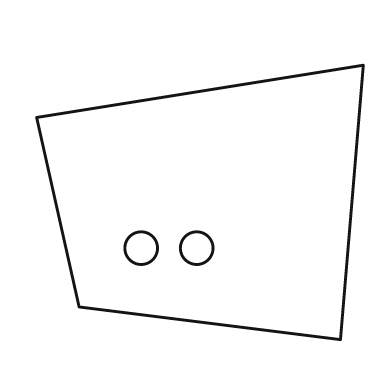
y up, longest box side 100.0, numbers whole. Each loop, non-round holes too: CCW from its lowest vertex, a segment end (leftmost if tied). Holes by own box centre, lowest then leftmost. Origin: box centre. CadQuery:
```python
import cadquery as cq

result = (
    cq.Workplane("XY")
    .moveTo(43.0, -42.0)
    .lineTo(50.0, 42.0)
    .lineTo(-50.0, 26.0)
    .lineTo(-37.0, -32.0)
    .close()
    .moveTo(-18.0, -14.0)
    .circle(5.0)
    .moveTo(-1.0, -14.0)
    .circle(5.0)
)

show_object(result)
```